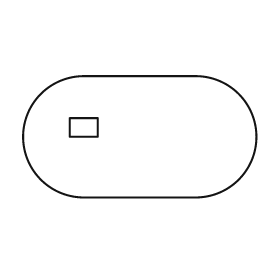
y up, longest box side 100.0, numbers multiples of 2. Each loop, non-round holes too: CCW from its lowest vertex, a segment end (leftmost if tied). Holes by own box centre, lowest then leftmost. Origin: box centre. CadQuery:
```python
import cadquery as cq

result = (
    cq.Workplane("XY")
    .moveTo(-24.0, -26.0)
    .lineTo(24.0, -26.0)
    .threePointArc((50.0, 0.0), (24.0, 26.0))
    .lineTo(-24.0, 26.0)
    .threePointArc((-50.0, 0.0), (-24.0, -26.0))
    .close()
    .moveTo(-30.0, 0.0)
    .lineTo(-18.0, 0.0)
    .lineTo(-18.0, 8.0)
    .lineTo(-30.0, 8.0)
    .close()
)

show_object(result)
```